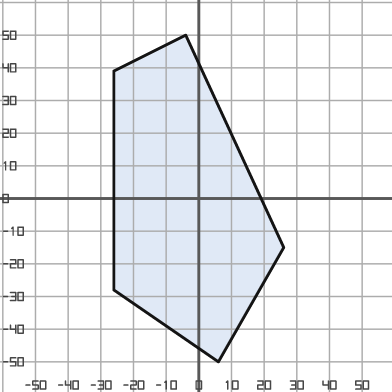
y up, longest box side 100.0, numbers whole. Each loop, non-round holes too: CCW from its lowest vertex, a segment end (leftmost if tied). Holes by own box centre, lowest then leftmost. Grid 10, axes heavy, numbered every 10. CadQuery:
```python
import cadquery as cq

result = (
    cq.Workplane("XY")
    .moveTo(6.0, -50.0)
    .lineTo(26.0, -15.0)
    .lineTo(-4.0, 50.0)
    .lineTo(-26.0, 39.0)
    .lineTo(-26.0, -28.0)
    .close()
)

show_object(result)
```